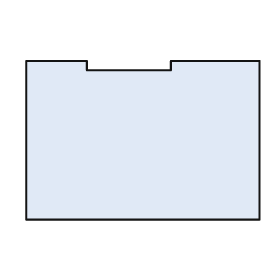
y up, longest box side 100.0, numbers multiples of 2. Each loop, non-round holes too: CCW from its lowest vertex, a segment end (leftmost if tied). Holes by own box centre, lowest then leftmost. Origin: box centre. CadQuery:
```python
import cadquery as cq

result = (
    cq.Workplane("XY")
    .moveTo(-50.0, -34.0)
    .lineTo(50.0, -34.0)
    .lineTo(50.0, 34.0)
    .lineTo(12.0, 34.0)
    .lineTo(12.0, 30.0)
    .lineTo(-24.0, 30.0)
    .lineTo(-24.0, 34.0)
    .lineTo(-50.0, 34.0)
    .close()
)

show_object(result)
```